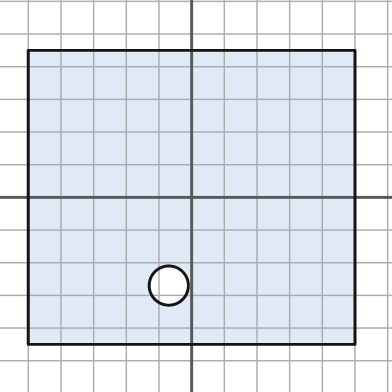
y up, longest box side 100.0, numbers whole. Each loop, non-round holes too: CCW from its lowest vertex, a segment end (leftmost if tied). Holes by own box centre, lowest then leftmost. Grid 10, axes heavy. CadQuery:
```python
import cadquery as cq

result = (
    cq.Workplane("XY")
    .moveTo(-50.0, -45.0)
    .lineTo(50.0, -45.0)
    .lineTo(50.0, 45.0)
    .lineTo(-50.0, 45.0)
    .close()
    .moveTo(-7.0, -27.0)
    .circle(6.0)
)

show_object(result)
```